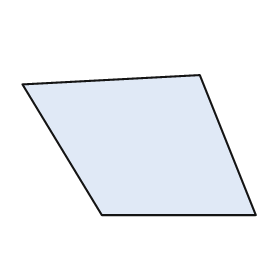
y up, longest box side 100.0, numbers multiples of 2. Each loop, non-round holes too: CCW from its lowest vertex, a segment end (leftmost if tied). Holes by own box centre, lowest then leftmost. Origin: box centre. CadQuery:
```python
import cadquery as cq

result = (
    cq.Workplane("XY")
    .moveTo(-16.0, -30.0)
    .lineTo(50.0, -30.0)
    .lineTo(26.0, 30.0)
    .lineTo(-50.0, 26.0)
    .close()
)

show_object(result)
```